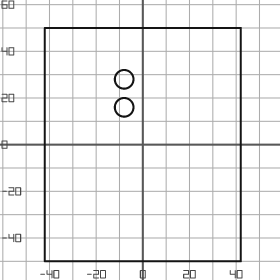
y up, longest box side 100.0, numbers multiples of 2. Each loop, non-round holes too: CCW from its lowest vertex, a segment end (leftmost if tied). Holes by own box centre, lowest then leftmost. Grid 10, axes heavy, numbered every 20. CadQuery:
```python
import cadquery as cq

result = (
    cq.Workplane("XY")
    .moveTo(-42.0, -50.0)
    .lineTo(42.0, -50.0)
    .lineTo(42.0, 50.0)
    .lineTo(-42.0, 50.0)
    .close()
    .moveTo(-8.0, 16.0)
    .circle(4.0)
    .moveTo(-8.0, 28.0)
    .circle(4.0)
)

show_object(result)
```